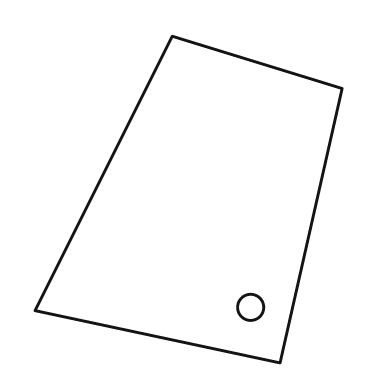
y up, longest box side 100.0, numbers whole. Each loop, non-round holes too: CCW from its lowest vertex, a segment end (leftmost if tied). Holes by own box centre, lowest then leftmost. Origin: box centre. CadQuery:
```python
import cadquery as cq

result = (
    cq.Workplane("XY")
    .moveTo(28.0, -50.0)
    .lineTo(47.0, 34.0)
    .lineTo(-5.0, 50.0)
    .lineTo(-47.0, -34.0)
    .close()
    .moveTo(19.0, -33.0)
    .circle(4.0)
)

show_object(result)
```